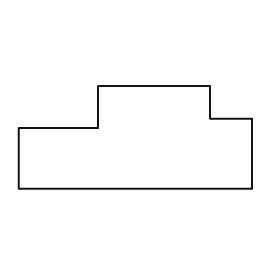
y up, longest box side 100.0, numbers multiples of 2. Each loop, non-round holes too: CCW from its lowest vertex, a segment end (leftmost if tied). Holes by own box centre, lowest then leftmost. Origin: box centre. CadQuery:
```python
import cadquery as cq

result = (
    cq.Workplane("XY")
    .moveTo(-50.0, -22.0)
    .lineTo(50.0, -22.0)
    .lineTo(50.0, 8.0)
    .lineTo(32.0, 8.0)
    .lineTo(32.0, 22.0)
    .lineTo(-16.0, 22.0)
    .lineTo(-16.0, 4.0)
    .lineTo(-50.0, 4.0)
    .close()
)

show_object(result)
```